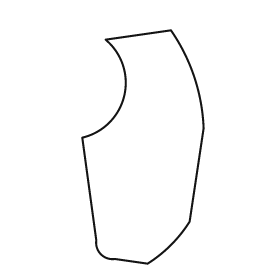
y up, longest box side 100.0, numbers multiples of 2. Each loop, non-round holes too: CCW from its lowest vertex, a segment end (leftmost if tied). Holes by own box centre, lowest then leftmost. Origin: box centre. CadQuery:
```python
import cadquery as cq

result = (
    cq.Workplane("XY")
    .moveTo(2.0, -50.0)
    .threePointArc((12.0, -42.0), (20.0, -32.0))
    .lineTo(26.0, 8.0)
    .threePointArc((22.0, 30.0), (12.0, 50.0))
    .lineTo(-16.0, 46.0)
    .threePointArc((-8.0, 22.0), (-26.0, 4.0))
    .lineTo(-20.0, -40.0)
    .threePointArc((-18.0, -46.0), (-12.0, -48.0))
    .close()
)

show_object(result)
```